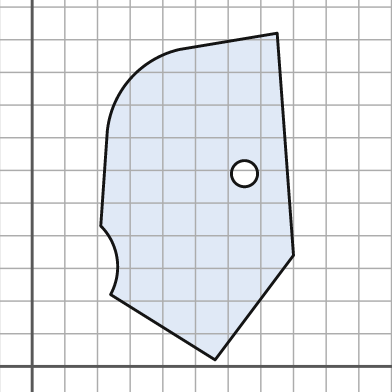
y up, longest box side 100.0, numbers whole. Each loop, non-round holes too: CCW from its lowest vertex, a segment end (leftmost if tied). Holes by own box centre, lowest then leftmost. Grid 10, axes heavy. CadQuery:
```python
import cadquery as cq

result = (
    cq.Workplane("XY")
    .moveTo(56.0, 2.0)
    .lineTo(80.0, 34.0)
    .lineTo(75.0, 102.0)
    .lineTo(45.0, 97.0)
    .threePointArc((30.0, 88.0), (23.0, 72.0))
    .lineTo(21.0, 43.0)
    .threePointArc((26.0, 33.0), (24.0, 22.0))
    .close()
    .moveTo(65.0, 59.0)
    .circle(4.0)
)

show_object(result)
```